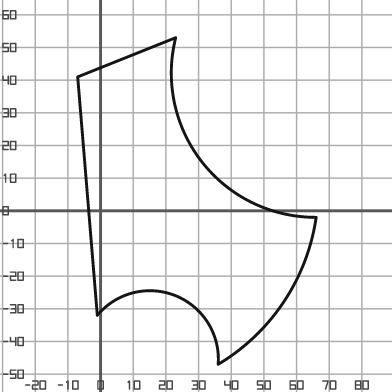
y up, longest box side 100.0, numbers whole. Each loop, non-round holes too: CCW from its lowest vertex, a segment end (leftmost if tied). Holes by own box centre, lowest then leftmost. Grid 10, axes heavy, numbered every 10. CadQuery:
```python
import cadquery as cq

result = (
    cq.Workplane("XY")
    .moveTo(36.0, -47.0)
    .threePointArc((56.0, -28.0), (66.0, -2.0))
    .threePointArc((31.0, 15.0), (23.0, 53.0))
    .lineTo(-7.0, 41.0)
    .lineTo(-1.0, -32.0)
    .threePointArc((23.0, -26.0), (36.0, -47.0))
    .close()
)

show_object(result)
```